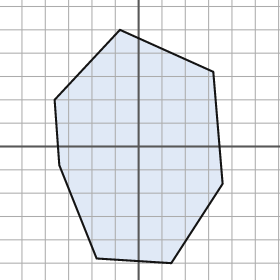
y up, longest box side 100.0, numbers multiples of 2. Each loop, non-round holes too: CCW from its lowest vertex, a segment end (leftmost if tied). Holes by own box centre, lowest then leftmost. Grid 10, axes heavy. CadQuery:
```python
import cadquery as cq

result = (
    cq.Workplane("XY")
    .moveTo(14.0, -50.0)
    .lineTo(36.0, -16.0)
    .lineTo(32.0, 32.0)
    .lineTo(-8.0, 50.0)
    .lineTo(-36.0, 20.0)
    .lineTo(-34.0, -8.0)
    .lineTo(-18.0, -48.0)
    .close()
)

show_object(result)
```